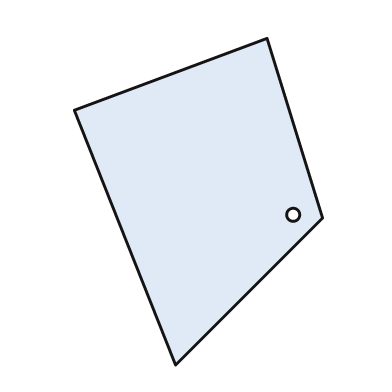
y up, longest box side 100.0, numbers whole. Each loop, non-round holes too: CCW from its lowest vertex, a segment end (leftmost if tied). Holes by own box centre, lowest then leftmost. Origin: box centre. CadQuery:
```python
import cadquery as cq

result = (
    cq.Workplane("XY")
    .moveTo(-7.0, -50.0)
    .lineTo(38.0, -5.0)
    .lineTo(21.0, 50.0)
    .lineTo(-38.0, 28.0)
    .close()
    .moveTo(29.0, -4.0)
    .circle(2.0)
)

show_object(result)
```